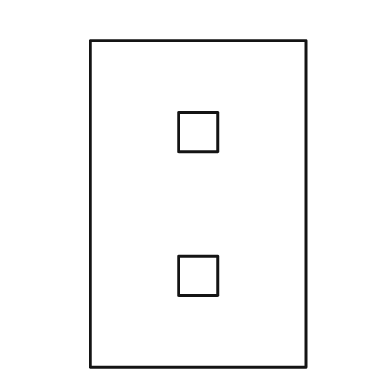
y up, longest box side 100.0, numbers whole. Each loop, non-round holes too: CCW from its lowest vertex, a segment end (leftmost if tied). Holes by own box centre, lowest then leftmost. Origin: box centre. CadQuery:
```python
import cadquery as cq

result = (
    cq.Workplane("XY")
    .moveTo(-33.0, -50.0)
    .lineTo(33.0, -50.0)
    .lineTo(33.0, 50.0)
    .lineTo(-33.0, 50.0)
    .close()
    .moveTo(-6.0, -28.0)
    .lineTo(6.0, -28.0)
    .lineTo(6.0, -16.0)
    .lineTo(-6.0, -16.0)
    .close()
    .moveTo(-6.0, 16.0)
    .lineTo(6.0, 16.0)
    .lineTo(6.0, 28.0)
    .lineTo(-6.0, 28.0)
    .close()
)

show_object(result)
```